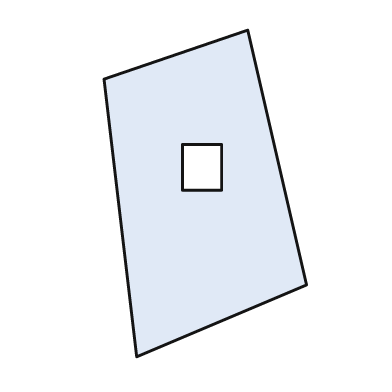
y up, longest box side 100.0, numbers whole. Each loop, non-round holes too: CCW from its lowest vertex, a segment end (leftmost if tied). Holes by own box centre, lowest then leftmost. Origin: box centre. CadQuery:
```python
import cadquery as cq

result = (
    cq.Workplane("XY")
    .moveTo(-21.0, -50.0)
    .lineTo(31.0, -28.0)
    .lineTo(13.0, 50.0)
    .lineTo(-31.0, 35.0)
    .close()
    .moveTo(-7.0, 1.0)
    .lineTo(5.0, 1.0)
    .lineTo(5.0, 15.0)
    .lineTo(-7.0, 15.0)
    .close()
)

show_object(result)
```